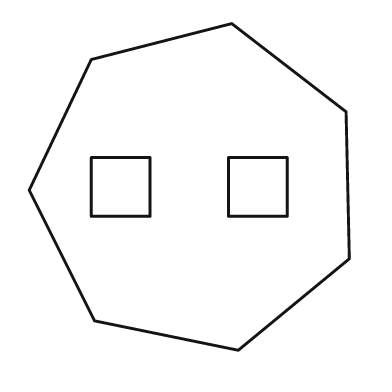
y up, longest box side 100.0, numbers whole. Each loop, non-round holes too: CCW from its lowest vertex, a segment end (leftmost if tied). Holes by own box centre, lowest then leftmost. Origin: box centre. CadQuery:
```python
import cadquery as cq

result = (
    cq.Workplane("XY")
    .moveTo(15.0, -50.0)
    .lineTo(49.0, -22.0)
    .lineTo(48.0, 23.0)
    .lineTo(13.0, 50.0)
    .lineTo(-30.0, 39.0)
    .lineTo(-49.0, -1.0)
    .lineTo(-29.0, -41.0)
    .close()
    .moveTo(-30.0, -9.0)
    .lineTo(-12.0, -9.0)
    .lineTo(-12.0, 9.0)
    .lineTo(-30.0, 9.0)
    .close()
    .moveTo(12.0, -9.0)
    .lineTo(30.0, -9.0)
    .lineTo(30.0, 9.0)
    .lineTo(12.0, 9.0)
    .close()
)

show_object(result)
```